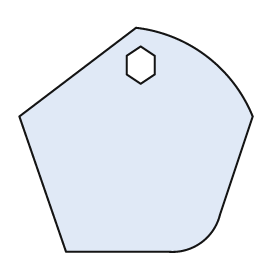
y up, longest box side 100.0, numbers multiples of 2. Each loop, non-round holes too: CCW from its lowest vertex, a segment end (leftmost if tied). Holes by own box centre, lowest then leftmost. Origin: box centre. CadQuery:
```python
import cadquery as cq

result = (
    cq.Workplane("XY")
    .moveTo(-30.0, -48.0)
    .lineTo(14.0, -48.0)
    .threePointArc((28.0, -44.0), (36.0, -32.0))
    .lineTo(50.0, 10.0)
    .threePointArc((30.0, 36.0), (0.0, 48.0))
    .lineTo(-50.0, 10.0)
    .close()
    .moveTo(2.0, 24.0)
    .lineTo(8.0, 28.0)
    .lineTo(8.0, 36.0)
    .lineTo(2.0, 40.0)
    .lineTo(-4.0, 36.0)
    .lineTo(-4.0, 28.0)
    .close()
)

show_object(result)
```